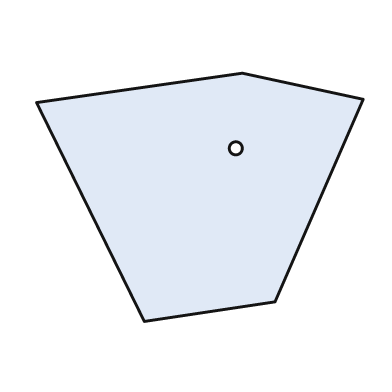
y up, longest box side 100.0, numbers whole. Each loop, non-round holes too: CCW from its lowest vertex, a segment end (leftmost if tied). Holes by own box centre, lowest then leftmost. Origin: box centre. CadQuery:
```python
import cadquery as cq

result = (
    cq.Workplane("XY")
    .moveTo(-17.0, -38.0)
    .lineTo(23.0, -32.0)
    .lineTo(50.0, 30.0)
    .lineTo(13.0, 38.0)
    .lineTo(-50.0, 29.0)
    .close()
    .moveTo(11.0, 15.0)
    .circle(2.0)
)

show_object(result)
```